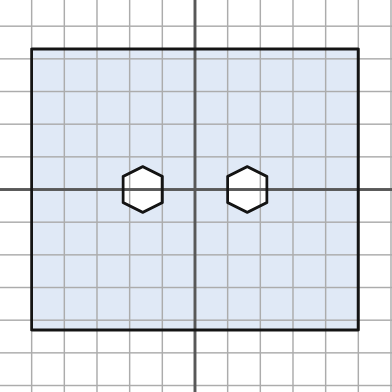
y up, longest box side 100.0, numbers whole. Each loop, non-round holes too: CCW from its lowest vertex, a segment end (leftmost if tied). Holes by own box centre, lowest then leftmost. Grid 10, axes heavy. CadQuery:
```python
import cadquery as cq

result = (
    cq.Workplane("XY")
    .moveTo(-50.0, -43.0)
    .lineTo(50.0, -43.0)
    .lineTo(50.0, 43.0)
    .lineTo(-50.0, 43.0)
    .close()
    .moveTo(-16.0, -7.0)
    .lineTo(-10.0, -4.0)
    .lineTo(-10.0, 4.0)
    .lineTo(-16.0, 7.0)
    .lineTo(-22.0, 4.0)
    .lineTo(-22.0, -4.0)
    .close()
    .moveTo(16.0, -7.0)
    .lineTo(22.0, -4.0)
    .lineTo(22.0, 4.0)
    .lineTo(16.0, 7.0)
    .lineTo(10.0, 4.0)
    .lineTo(10.0, -4.0)
    .close()
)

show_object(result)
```